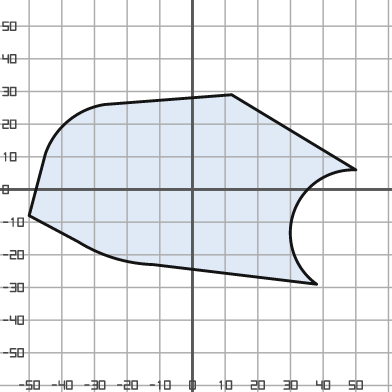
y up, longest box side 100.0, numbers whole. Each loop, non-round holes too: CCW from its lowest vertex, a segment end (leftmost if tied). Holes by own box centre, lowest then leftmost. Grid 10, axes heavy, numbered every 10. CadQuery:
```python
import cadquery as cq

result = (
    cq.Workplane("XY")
    .moveTo(38.0, -29.0)
    .threePointArc((31.0, -7.0), (50.0, 6.0))
    .lineTo(12.0, 29.0)
    .lineTo(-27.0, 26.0)
    .threePointArc((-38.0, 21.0), (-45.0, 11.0))
    .lineTo(-50.0, -8.0)
    .lineTo(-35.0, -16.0)
    .threePointArc((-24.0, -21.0), (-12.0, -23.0))
    .close()
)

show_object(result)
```